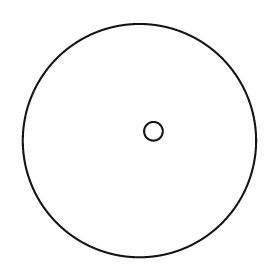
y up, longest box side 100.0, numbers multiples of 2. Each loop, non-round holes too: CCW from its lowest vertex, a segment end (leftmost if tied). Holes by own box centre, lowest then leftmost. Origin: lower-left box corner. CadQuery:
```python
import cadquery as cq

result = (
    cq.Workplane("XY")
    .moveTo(50.0, 50.0)
    .circle(50.0)
    .moveTo(56.0, 54.0)
    .circle(4.0)
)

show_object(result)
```